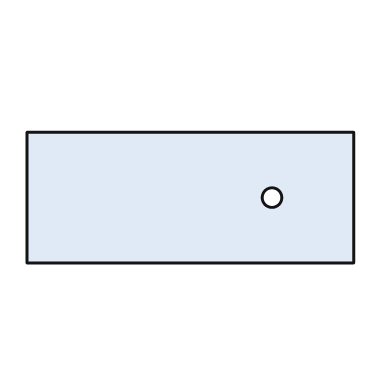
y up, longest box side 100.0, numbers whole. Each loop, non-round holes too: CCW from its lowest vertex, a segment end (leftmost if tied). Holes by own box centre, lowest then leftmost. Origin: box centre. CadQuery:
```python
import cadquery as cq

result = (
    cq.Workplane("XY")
    .moveTo(-50.0, -20.0)
    .lineTo(50.0, -20.0)
    .lineTo(50.0, 20.0)
    .lineTo(-50.0, 20.0)
    .close()
    .moveTo(25.0, 0.0)
    .circle(3.0)
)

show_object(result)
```